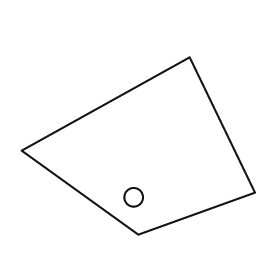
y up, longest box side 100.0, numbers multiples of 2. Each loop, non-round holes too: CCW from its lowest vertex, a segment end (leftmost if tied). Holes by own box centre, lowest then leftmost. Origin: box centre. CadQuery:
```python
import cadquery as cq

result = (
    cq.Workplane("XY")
    .moveTo(0.0, -38.0)
    .lineTo(50.0, -20.0)
    .lineTo(22.0, 38.0)
    .lineTo(-50.0, -2.0)
    .close()
    .moveTo(-2.0, -22.0)
    .circle(4.0)
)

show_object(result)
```